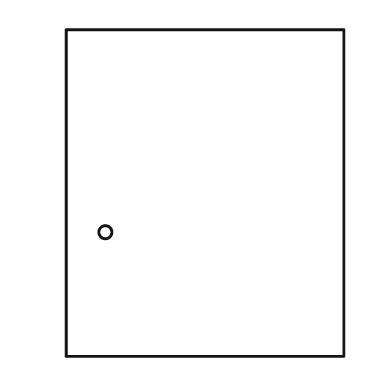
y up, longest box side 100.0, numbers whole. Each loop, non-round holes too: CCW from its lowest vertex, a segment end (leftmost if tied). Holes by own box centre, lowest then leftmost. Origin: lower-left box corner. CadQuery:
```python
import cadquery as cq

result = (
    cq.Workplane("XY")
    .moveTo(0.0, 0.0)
    .lineTo(85.0, 0.0)
    .lineTo(85.0, 100.0)
    .lineTo(0.0, 100.0)
    .close()
    .moveTo(12.0, 38.0)
    .circle(2.0)
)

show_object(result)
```